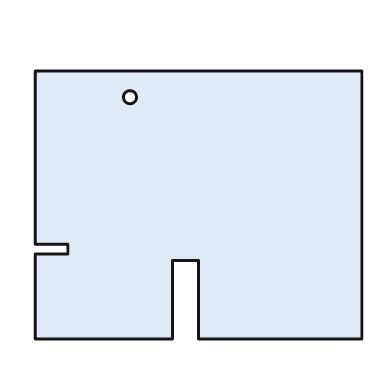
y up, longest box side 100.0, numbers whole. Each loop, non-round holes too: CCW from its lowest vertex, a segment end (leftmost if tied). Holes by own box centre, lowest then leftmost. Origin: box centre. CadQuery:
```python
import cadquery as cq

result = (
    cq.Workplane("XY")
    .moveTo(-50.0, -41.0)
    .lineTo(-8.0, -41.0)
    .lineTo(-8.0, -17.0)
    .lineTo(0.0, -17.0)
    .lineTo(0.0, -41.0)
    .lineTo(50.0, -41.0)
    .lineTo(50.0, 41.0)
    .lineTo(-50.0, 41.0)
    .lineTo(-50.0, -12.0)
    .lineTo(-40.0, -12.0)
    .lineTo(-40.0, -15.0)
    .lineTo(-50.0, -15.0)
    .close()
    .moveTo(-21.0, 33.0)
    .circle(2.0)
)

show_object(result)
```